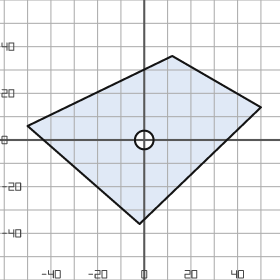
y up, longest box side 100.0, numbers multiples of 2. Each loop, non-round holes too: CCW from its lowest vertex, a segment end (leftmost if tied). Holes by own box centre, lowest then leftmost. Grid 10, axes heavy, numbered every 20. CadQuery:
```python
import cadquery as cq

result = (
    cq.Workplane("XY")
    .moveTo(-2.0, -36.0)
    .lineTo(50.0, 14.0)
    .lineTo(12.0, 36.0)
    .lineTo(-50.0, 6.0)
    .close()
    .moveTo(0.0, 0.0)
    .circle(4.0)
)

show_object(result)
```